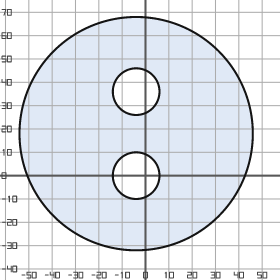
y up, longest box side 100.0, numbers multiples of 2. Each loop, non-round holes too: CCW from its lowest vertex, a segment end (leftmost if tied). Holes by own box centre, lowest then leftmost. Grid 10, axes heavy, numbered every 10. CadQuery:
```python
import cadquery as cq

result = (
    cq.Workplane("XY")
    .moveTo(-4.0, 18.0)
    .circle(50.0)
    .moveTo(-4.0, 0.0)
    .circle(10.0)
    .moveTo(-4.0, 36.0)
    .circle(10.0)
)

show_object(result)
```